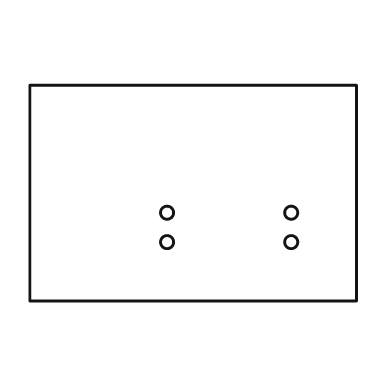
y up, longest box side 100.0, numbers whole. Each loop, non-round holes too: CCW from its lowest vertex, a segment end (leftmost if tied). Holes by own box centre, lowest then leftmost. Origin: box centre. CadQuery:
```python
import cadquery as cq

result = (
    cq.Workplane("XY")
    .moveTo(-50.0, -33.0)
    .lineTo(50.0, -33.0)
    .lineTo(50.0, 33.0)
    .lineTo(-50.0, 33.0)
    .close()
    .moveTo(-8.0, -15.0)
    .circle(2.0)
    .moveTo(30.0, -15.0)
    .circle(2.0)
    .moveTo(-8.0, -6.0)
    .circle(2.0)
    .moveTo(30.0, -6.0)
    .circle(2.0)
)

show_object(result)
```